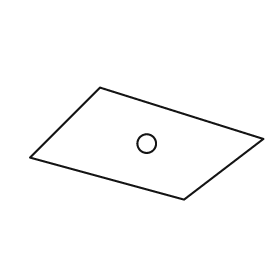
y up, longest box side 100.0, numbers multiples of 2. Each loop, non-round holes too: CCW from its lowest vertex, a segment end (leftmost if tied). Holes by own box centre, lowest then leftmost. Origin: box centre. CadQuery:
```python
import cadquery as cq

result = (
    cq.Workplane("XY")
    .moveTo(16.0, -24.0)
    .lineTo(50.0, 2.0)
    .lineTo(-20.0, 24.0)
    .lineTo(-50.0, -6.0)
    .close()
    .moveTo(0.0, 0.0)
    .circle(4.0)
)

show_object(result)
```